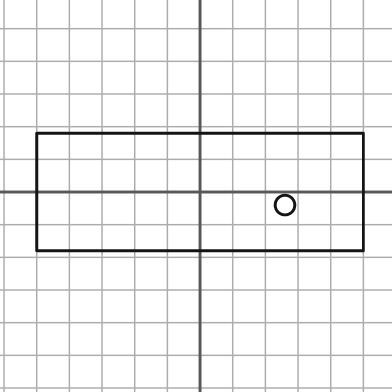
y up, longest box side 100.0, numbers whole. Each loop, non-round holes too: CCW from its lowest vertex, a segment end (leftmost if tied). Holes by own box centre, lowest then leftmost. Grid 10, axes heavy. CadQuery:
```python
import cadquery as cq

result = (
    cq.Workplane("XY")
    .moveTo(-50.0, -18.0)
    .lineTo(50.0, -18.0)
    .lineTo(50.0, 18.0)
    .lineTo(-50.0, 18.0)
    .close()
    .moveTo(26.0, -4.0)
    .circle(3.0)
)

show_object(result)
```